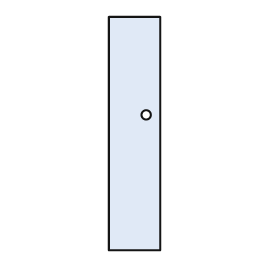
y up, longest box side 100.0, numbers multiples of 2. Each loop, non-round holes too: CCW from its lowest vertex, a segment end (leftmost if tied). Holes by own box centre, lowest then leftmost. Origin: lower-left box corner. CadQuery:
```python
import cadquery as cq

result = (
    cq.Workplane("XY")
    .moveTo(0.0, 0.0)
    .lineTo(22.0, 0.0)
    .lineTo(22.0, 100.0)
    .lineTo(0.0, 100.0)
    .close()
    .moveTo(16.0, 58.0)
    .circle(2.0)
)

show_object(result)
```